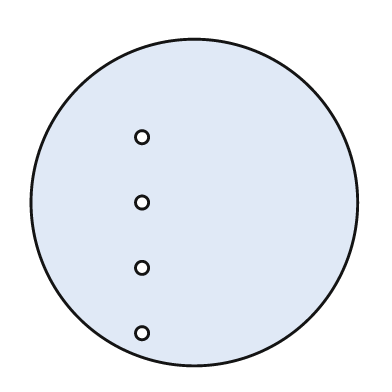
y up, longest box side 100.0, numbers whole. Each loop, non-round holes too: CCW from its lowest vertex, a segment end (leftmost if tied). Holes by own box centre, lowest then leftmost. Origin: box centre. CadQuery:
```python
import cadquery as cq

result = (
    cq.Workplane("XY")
    .moveTo(0.0, 0.0)
    .circle(50.0)
    .moveTo(-16.0, -40.0)
    .circle(2.0)
    .moveTo(-16.0, -20.0)
    .circle(2.0)
    .moveTo(-16.0, 0.0)
    .circle(2.0)
    .moveTo(-16.0, 20.0)
    .circle(2.0)
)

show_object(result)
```